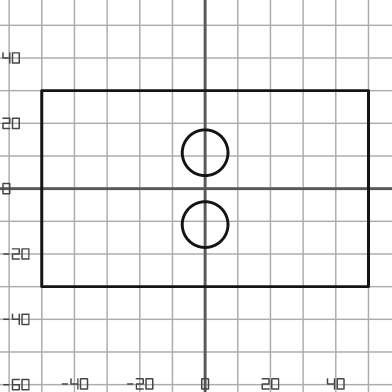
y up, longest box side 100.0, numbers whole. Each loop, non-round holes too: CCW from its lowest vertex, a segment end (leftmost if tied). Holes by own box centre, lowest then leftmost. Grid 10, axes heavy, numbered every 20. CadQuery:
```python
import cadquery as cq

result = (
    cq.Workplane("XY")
    .moveTo(-50.0, -30.0)
    .lineTo(50.0, -30.0)
    .lineTo(50.0, 30.0)
    .lineTo(-50.0, 30.0)
    .close()
    .moveTo(0.0, -11.0)
    .circle(7.0)
    .moveTo(0.0, 11.0)
    .circle(7.0)
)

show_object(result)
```